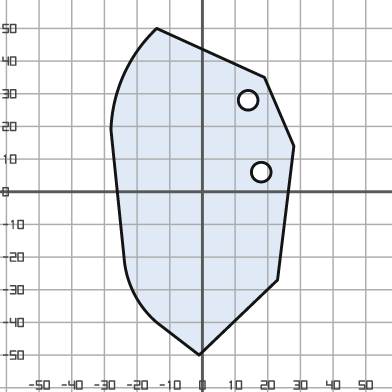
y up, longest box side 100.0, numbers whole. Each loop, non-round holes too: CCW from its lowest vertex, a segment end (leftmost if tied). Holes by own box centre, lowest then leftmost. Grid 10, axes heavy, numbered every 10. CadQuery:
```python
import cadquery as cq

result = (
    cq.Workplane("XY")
    .moveTo(-1.0, -50.0)
    .lineTo(23.0, -27.0)
    .lineTo(28.0, 14.0)
    .lineTo(19.0, 35.0)
    .lineTo(-14.0, 50.0)
    .threePointArc((-24.0, 36.0), (-28.0, 19.0))
    .lineTo(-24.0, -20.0)
    .threePointArc((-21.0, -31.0), (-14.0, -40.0))
    .close()
    .moveTo(18.0, 6.0)
    .circle(3.0)
    .moveTo(14.0, 28.0)
    .circle(3.0)
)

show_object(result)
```